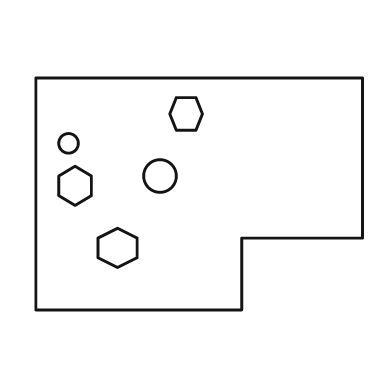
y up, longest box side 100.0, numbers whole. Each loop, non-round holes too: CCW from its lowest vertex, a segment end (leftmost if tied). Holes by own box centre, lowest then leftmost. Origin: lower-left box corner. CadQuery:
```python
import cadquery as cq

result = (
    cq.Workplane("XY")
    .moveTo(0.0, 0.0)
    .lineTo(63.0, 0.0)
    .lineTo(63.0, 22.0)
    .lineTo(100.0, 22.0)
    .lineTo(100.0, 71.0)
    .lineTo(0.0, 71.0)
    .close()
    .moveTo(25.0, 13.0)
    .lineTo(31.0, 16.0)
    .lineTo(31.0, 22.0)
    .lineTo(25.0, 25.0)
    .lineTo(19.0, 22.0)
    .lineTo(19.0, 16.0)
    .close()
    .moveTo(12.0, 32.0)
    .lineTo(17.0, 35.0)
    .lineTo(17.0, 41.0)
    .lineTo(12.0, 44.0)
    .lineTo(7.0, 41.0)
    .lineTo(7.0, 35.0)
    .close()
    .moveTo(38.0, 41.0)
    .circle(5.0)
    .moveTo(10.0, 51.0)
    .circle(3.0)
    .moveTo(43.0, 55.0)
    .lineTo(49.0, 55.0)
    .lineTo(51.0, 60.0)
    .lineTo(49.0, 65.0)
    .lineTo(43.0, 65.0)
    .lineTo(41.0, 60.0)
    .close()
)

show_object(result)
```